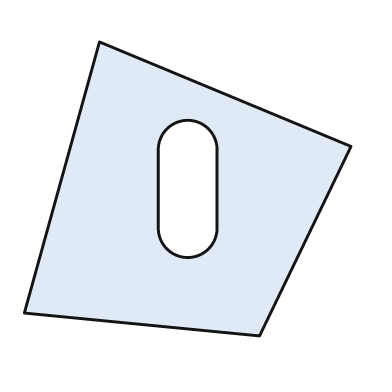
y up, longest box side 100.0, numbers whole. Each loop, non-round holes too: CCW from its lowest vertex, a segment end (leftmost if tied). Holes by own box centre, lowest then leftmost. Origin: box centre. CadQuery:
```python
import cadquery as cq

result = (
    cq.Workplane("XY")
    .moveTo(22.0, -45.0)
    .lineTo(50.0, 13.0)
    .lineTo(-27.0, 45.0)
    .lineTo(-50.0, -38.0)
    .close()
    .moveTo(-9.0, -12.0)
    .threePointArc((0.0, -21.0), (9.0, -12.0))
    .lineTo(9.0, 12.0)
    .threePointArc((0.0, 21.0), (-9.0, 12.0))
    .close()
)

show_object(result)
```